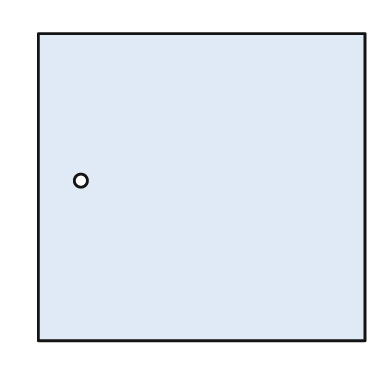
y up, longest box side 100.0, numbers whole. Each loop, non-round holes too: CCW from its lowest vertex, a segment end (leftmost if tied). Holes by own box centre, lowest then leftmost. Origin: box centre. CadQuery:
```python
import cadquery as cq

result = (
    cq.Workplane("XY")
    .moveTo(-50.0, -47.0)
    .lineTo(50.0, -47.0)
    .lineTo(50.0, 47.0)
    .lineTo(-50.0, 47.0)
    .close()
    .moveTo(-37.0, 2.0)
    .circle(2.0)
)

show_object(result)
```